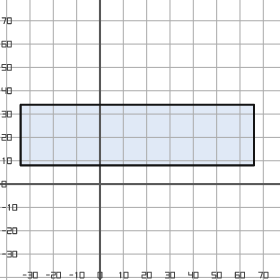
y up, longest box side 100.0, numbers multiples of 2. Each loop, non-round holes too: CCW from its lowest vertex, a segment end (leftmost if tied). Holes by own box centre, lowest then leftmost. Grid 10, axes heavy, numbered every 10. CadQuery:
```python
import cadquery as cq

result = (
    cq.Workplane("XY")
    .moveTo(-34.0, 8.0)
    .lineTo(66.0, 8.0)
    .lineTo(66.0, 34.0)
    .lineTo(-34.0, 34.0)
    .close()
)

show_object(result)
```